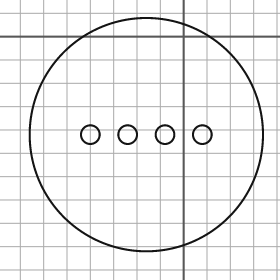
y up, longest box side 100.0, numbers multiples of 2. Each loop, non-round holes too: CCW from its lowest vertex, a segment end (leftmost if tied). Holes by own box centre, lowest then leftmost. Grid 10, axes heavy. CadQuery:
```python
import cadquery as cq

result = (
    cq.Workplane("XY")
    .moveTo(-16.0, -42.0)
    .circle(50.0)
    .moveTo(-40.0, -42.0)
    .circle(4.0)
    .moveTo(-24.0, -42.0)
    .circle(4.0)
    .moveTo(-8.0, -42.0)
    .circle(4.0)
    .moveTo(8.0, -42.0)
    .circle(4.0)
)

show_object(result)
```